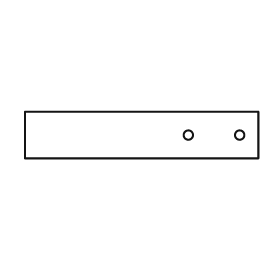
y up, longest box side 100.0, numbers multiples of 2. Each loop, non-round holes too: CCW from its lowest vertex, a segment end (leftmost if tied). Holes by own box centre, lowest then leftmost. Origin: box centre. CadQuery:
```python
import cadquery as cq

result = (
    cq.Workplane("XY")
    .moveTo(-50.0, -10.0)
    .lineTo(50.0, -10.0)
    .lineTo(50.0, 10.0)
    .lineTo(-50.0, 10.0)
    .close()
    .moveTo(20.0, 0.0)
    .circle(2.0)
    .moveTo(42.0, 0.0)
    .circle(2.0)
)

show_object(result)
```